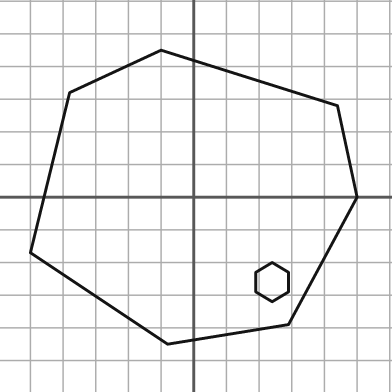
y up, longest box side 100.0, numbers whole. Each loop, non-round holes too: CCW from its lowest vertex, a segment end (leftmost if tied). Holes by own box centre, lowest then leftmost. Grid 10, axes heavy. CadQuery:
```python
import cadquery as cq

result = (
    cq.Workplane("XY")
    .moveTo(-8.0, -45.0)
    .lineTo(29.0, -39.0)
    .lineTo(50.0, 0.0)
    .lineTo(44.0, 28.0)
    .lineTo(-10.0, 45.0)
    .lineTo(-38.0, 32.0)
    .lineTo(-50.0, -17.0)
    .close()
    .moveTo(24.0, -32.0)
    .lineTo(29.0, -29.0)
    .lineTo(29.0, -23.0)
    .lineTo(24.0, -20.0)
    .lineTo(19.0, -23.0)
    .lineTo(19.0, -29.0)
    .close()
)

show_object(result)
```